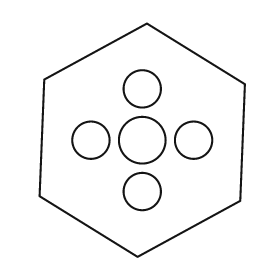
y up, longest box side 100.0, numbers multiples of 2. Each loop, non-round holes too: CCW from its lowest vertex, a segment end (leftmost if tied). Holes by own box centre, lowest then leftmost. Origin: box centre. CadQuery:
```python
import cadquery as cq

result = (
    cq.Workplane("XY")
    .moveTo(-2.0, -50.0)
    .lineTo(42.0, -26.0)
    .lineTo(44.0, 24.0)
    .lineTo(2.0, 50.0)
    .lineTo(-42.0, 26.0)
    .lineTo(-44.0, -24.0)
    .close()
    .moveTo(0.0, -22.0)
    .circle(8.0)
    .moveTo(-22.0, 0.0)
    .circle(8.0)
    .moveTo(0.0, 0.0)
    .circle(10.0)
    .moveTo(22.0, 0.0)
    .circle(8.0)
    .moveTo(0.0, 22.0)
    .circle(8.0)
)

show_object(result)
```